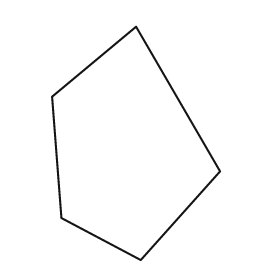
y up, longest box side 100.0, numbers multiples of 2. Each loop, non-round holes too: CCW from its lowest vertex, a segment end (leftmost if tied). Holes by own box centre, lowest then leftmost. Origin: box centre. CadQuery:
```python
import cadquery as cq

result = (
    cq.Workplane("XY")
    .moveTo(2.0, -50.0)
    .lineTo(36.0, -12.0)
    .lineTo(0.0, 50.0)
    .lineTo(-36.0, 20.0)
    .lineTo(-32.0, -32.0)
    .close()
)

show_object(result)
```